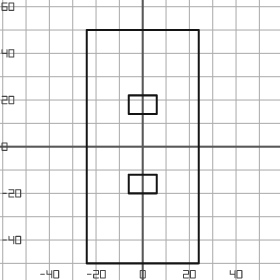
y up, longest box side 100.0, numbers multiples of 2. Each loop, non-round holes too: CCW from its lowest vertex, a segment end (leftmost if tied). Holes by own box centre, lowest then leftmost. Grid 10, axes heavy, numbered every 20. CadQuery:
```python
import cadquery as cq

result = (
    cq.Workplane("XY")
    .moveTo(-24.0, -50.0)
    .lineTo(24.0, -50.0)
    .lineTo(24.0, 50.0)
    .lineTo(-24.0, 50.0)
    .close()
    .moveTo(-6.0, -20.0)
    .lineTo(6.0, -20.0)
    .lineTo(6.0, -12.0)
    .lineTo(-6.0, -12.0)
    .close()
    .moveTo(-6.0, 14.0)
    .lineTo(6.0, 14.0)
    .lineTo(6.0, 22.0)
    .lineTo(-6.0, 22.0)
    .close()
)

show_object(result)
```